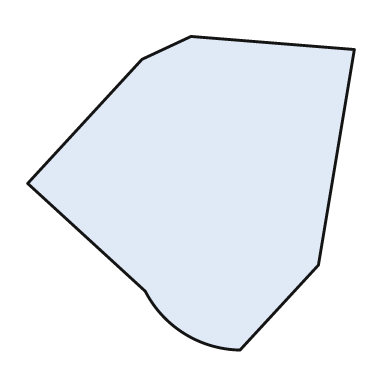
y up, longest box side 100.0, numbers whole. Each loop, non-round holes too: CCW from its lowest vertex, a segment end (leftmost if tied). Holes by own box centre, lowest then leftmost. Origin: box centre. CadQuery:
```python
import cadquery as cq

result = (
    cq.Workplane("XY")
    .moveTo(15.0, -48.0)
    .lineTo(39.0, -22.0)
    .lineTo(50.0, 44.0)
    .lineTo(0.0, 48.0)
    .lineTo(-15.0, 41.0)
    .lineTo(-50.0, 3.0)
    .lineTo(-14.0, -30.0)
    .threePointArc((-2.0, -43.0), (15.0, -48.0))
    .close()
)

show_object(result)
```